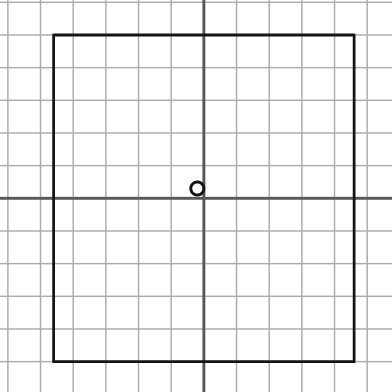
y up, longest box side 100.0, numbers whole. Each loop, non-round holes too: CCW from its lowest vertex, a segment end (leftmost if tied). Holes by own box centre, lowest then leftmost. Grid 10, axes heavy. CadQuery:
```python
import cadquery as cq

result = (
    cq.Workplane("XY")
    .moveTo(-46.0, -50.0)
    .lineTo(46.0, -50.0)
    .lineTo(46.0, 50.0)
    .lineTo(-46.0, 50.0)
    .close()
    .moveTo(-2.0, 3.0)
    .circle(2.0)
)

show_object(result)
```